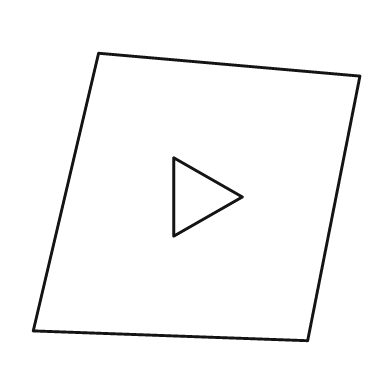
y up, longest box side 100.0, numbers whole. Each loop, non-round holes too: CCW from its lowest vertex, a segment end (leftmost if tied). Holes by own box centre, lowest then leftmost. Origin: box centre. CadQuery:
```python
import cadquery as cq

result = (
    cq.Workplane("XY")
    .moveTo(34.0, -44.0)
    .lineTo(50.0, 37.0)
    .lineTo(-30.0, 44.0)
    .lineTo(-50.0, -41.0)
    .close()
    .moveTo(-7.0, -12.0)
    .lineTo(14.0, 0.0)
    .lineTo(-7.0, 12.0)
    .close()
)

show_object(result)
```